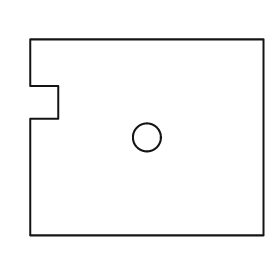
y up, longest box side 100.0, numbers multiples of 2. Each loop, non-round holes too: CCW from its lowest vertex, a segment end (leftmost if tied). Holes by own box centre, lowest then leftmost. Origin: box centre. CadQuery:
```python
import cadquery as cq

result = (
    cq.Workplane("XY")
    .moveTo(-50.0, -42.0)
    .lineTo(50.0, -42.0)
    .lineTo(50.0, 42.0)
    .lineTo(-50.0, 42.0)
    .lineTo(-50.0, 22.0)
    .lineTo(-38.0, 22.0)
    .lineTo(-38.0, 8.0)
    .lineTo(-50.0, 8.0)
    .close()
    .moveTo(0.0, 0.0)
    .circle(6.0)
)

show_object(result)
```